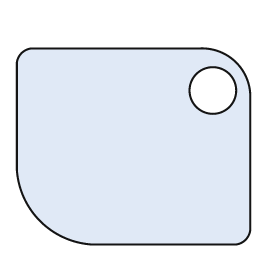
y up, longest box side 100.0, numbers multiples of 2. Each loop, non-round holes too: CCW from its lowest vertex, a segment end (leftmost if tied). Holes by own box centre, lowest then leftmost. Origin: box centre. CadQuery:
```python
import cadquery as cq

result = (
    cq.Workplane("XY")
    .moveTo(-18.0, -42.0)
    .lineTo(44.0, -42.0)
    .threePointArc((48.0, -40.0), (50.0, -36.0))
    .lineTo(50.0, 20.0)
    .threePointArc((44.0, 36.0), (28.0, 42.0))
    .lineTo(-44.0, 42.0)
    .threePointArc((-48.0, 40.0), (-50.0, 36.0))
    .lineTo(-50.0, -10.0)
    .threePointArc((-40.0, -32.0), (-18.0, -42.0))
    .close()
    .moveTo(34.0, 24.0)
    .circle(10.0)
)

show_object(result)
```